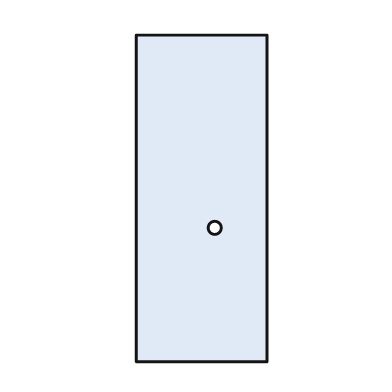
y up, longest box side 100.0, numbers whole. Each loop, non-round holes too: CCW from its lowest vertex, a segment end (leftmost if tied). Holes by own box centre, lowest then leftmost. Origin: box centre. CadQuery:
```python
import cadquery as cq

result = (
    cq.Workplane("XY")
    .moveTo(-20.0, -50.0)
    .lineTo(20.0, -50.0)
    .lineTo(20.0, 50.0)
    .lineTo(-20.0, 50.0)
    .close()
    .moveTo(4.0, -9.0)
    .circle(2.0)
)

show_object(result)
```